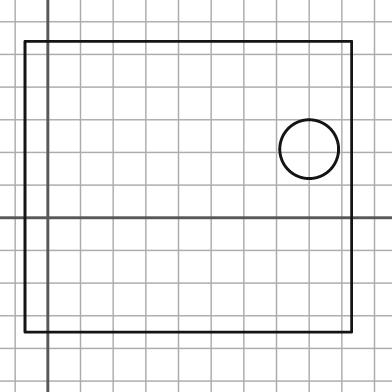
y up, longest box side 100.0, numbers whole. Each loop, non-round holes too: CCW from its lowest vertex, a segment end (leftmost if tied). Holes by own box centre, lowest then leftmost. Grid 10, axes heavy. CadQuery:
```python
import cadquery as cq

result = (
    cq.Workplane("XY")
    .moveTo(-7.0, -35.0)
    .lineTo(93.0, -35.0)
    .lineTo(93.0, 54.0)
    .lineTo(-7.0, 54.0)
    .close()
    .moveTo(80.0, 21.0)
    .circle(9.0)
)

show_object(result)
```